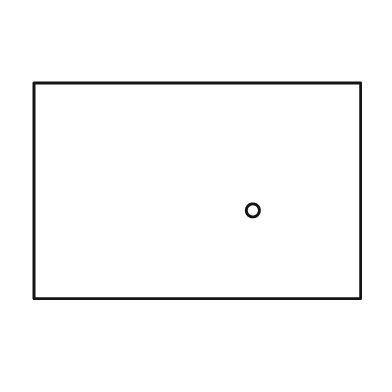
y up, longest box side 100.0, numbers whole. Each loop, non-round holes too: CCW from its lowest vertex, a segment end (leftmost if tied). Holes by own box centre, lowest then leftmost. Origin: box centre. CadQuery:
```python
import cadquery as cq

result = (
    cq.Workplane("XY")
    .moveTo(-50.0, -33.0)
    .lineTo(50.0, -33.0)
    .lineTo(50.0, 33.0)
    .lineTo(-50.0, 33.0)
    .close()
    .moveTo(17.0, -6.0)
    .circle(2.0)
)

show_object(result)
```